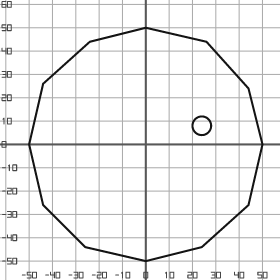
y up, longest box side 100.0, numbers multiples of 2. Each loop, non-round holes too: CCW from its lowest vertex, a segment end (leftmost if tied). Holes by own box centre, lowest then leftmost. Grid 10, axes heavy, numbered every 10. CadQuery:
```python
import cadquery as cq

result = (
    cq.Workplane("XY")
    .moveTo(0.0, -50.0)
    .lineTo(24.0, -44.0)
    .lineTo(44.0, -26.0)
    .lineTo(50.0, 0.0)
    .lineTo(44.0, 24.0)
    .lineTo(26.0, 44.0)
    .lineTo(0.0, 50.0)
    .lineTo(-24.0, 44.0)
    .lineTo(-44.0, 26.0)
    .lineTo(-50.0, 0.0)
    .lineTo(-44.0, -26.0)
    .lineTo(-26.0, -44.0)
    .close()
    .moveTo(24.0, 8.0)
    .circle(4.0)
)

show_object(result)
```